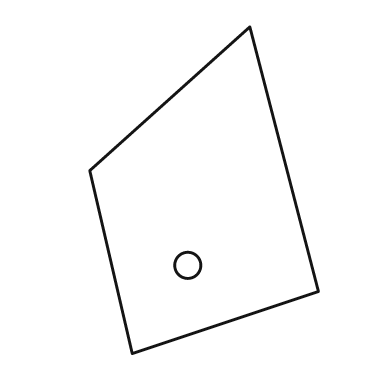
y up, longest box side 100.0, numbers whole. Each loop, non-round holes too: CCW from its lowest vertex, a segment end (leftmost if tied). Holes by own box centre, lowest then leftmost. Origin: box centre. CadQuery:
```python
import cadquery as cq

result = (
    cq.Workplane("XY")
    .moveTo(-22.0, -50.0)
    .lineTo(35.0, -31.0)
    .lineTo(14.0, 50.0)
    .lineTo(-35.0, 6.0)
    .close()
    .moveTo(-5.0, -23.0)
    .circle(4.0)
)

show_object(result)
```